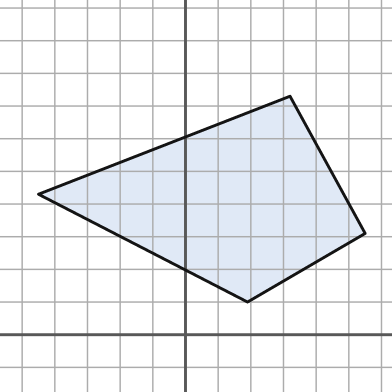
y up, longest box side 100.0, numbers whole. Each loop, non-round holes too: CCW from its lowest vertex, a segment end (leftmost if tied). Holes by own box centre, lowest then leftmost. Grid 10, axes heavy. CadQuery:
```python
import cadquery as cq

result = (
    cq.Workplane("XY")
    .moveTo(19.0, 10.0)
    .lineTo(55.0, 31.0)
    .lineTo(32.0, 73.0)
    .lineTo(-45.0, 43.0)
    .close()
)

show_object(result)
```